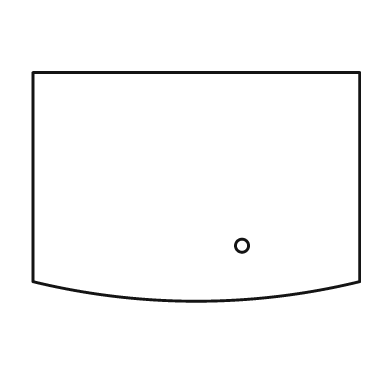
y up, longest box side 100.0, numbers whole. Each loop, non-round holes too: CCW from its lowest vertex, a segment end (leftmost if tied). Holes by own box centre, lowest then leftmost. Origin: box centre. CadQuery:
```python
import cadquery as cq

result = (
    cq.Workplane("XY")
    .moveTo(-50.0, -29.0)
    .threePointArc((0.0, -35.0), (50.0, -29.0))
    .lineTo(50.0, 35.0)
    .lineTo(-50.0, 35.0)
    .close()
    .moveTo(14.0, -18.0)
    .circle(2.0)
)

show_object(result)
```